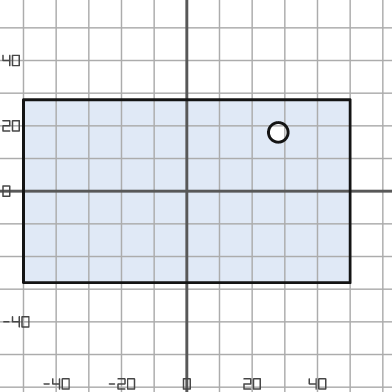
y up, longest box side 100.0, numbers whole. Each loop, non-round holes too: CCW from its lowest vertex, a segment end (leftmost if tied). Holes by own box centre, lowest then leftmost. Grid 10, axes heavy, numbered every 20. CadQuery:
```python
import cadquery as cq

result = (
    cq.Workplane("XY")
    .moveTo(-50.0, -28.0)
    .lineTo(50.0, -28.0)
    .lineTo(50.0, 28.0)
    .lineTo(-50.0, 28.0)
    .close()
    .moveTo(28.0, 18.0)
    .circle(3.0)
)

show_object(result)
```